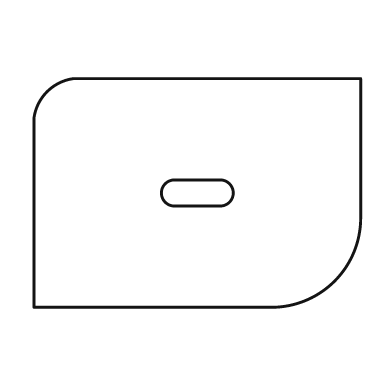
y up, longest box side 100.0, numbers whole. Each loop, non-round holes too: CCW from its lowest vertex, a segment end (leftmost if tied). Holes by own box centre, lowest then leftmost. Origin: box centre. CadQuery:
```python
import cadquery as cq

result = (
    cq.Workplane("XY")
    .moveTo(-50.0, -35.0)
    .lineTo(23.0, -35.0)
    .threePointArc((42.0, -27.0), (50.0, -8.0))
    .lineTo(50.0, 35.0)
    .lineTo(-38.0, 35.0)
    .threePointArc((-46.0, 31.0), (-50.0, 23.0))
    .close()
    .moveTo(-7.0, -4.0)
    .lineTo(7.0, -4.0)
    .threePointArc((11.0, 0.0), (7.0, 4.0))
    .lineTo(-7.0, 4.0)
    .threePointArc((-11.0, 0.0), (-7.0, -4.0))
    .close()
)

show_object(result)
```